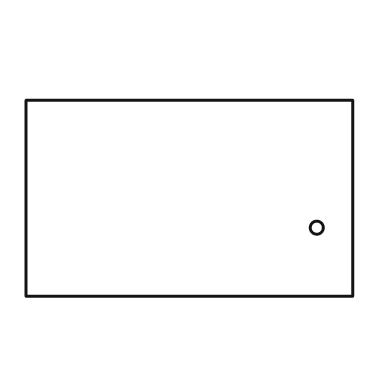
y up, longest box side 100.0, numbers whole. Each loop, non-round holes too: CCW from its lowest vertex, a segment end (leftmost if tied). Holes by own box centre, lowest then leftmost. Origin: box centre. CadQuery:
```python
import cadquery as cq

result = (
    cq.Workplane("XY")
    .moveTo(-50.0, -30.0)
    .lineTo(50.0, -30.0)
    .lineTo(50.0, 30.0)
    .lineTo(-50.0, 30.0)
    .close()
    .moveTo(39.0, -9.0)
    .circle(2.0)
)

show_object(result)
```